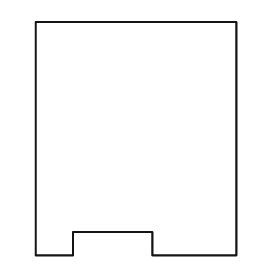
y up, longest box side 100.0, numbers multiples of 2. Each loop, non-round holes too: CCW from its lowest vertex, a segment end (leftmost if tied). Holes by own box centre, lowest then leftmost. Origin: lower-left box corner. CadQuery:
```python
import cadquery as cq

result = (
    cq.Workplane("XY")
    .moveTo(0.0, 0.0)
    .lineTo(16.0, 0.0)
    .lineTo(16.0, 10.0)
    .lineTo(50.0, 10.0)
    .lineTo(50.0, 0.0)
    .lineTo(86.0, 0.0)
    .lineTo(86.0, 100.0)
    .lineTo(0.0, 100.0)
    .close()
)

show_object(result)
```